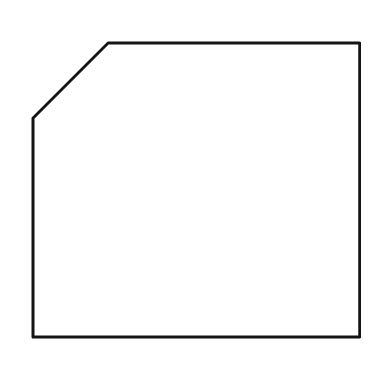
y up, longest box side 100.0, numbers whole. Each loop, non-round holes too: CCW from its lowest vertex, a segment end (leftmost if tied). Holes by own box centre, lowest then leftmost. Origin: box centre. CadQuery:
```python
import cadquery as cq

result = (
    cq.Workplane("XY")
    .moveTo(-50.0, -45.0)
    .lineTo(50.0, -45.0)
    .lineTo(50.0, 45.0)
    .lineTo(-27.0, 45.0)
    .lineTo(-50.0, 22.0)
    .close()
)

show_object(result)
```